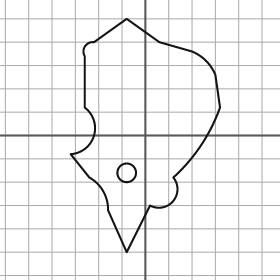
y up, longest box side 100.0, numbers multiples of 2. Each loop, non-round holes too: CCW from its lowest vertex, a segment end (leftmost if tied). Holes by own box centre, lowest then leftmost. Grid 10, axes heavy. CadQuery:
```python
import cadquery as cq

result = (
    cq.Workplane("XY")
    .moveTo(-8.0, -50.0)
    .lineTo(2.0, -30.0)
    .threePointArc((12.0, -28.0), (12.0, -18.0))
    .threePointArc((24.0, -4.0), (32.0, 12.0))
    .lineTo(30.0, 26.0)
    .threePointArc((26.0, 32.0), (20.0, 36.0))
    .lineTo(6.0, 40.0)
    .lineTo(-8.0, 50.0)
    .lineTo(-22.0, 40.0)
    .threePointArc((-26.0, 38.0), (-26.0, 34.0))
    .lineTo(-26.0, 12.0)
    .threePointArc((-22.0, 0.0), (-32.0, -8.0))
    .lineTo(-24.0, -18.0)
    .threePointArc((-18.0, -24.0), (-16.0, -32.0))
    .close()
    .moveTo(-8.0, -16.0)
    .circle(4.0)
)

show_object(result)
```